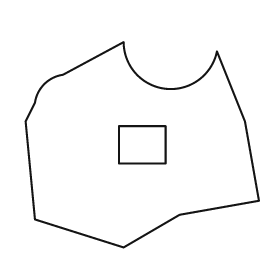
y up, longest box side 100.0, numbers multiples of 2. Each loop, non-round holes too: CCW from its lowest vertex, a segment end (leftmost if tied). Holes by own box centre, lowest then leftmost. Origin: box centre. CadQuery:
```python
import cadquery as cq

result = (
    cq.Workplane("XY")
    .moveTo(-8.0, -44.0)
    .lineTo(16.0, -30.0)
    .lineTo(50.0, -24.0)
    .lineTo(44.0, 10.0)
    .lineTo(32.0, 40.0)
    .threePointArc((10.0, 24.0), (-8.0, 44.0))
    .lineTo(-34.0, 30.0)
    .threePointArc((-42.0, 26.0), (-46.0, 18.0))
    .lineTo(-50.0, 10.0)
    .lineTo(-46.0, -32.0)
    .close()
    .moveTo(-10.0, -8.0)
    .lineTo(10.0, -8.0)
    .lineTo(10.0, 8.0)
    .lineTo(-10.0, 8.0)
    .close()
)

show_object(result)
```